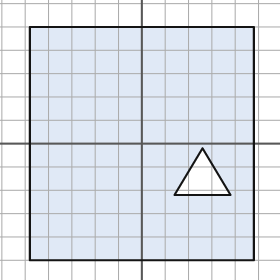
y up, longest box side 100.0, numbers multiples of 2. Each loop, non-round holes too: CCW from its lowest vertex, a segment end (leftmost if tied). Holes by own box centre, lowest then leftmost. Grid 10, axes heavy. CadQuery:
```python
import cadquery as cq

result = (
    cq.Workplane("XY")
    .moveTo(-48.0, -50.0)
    .lineTo(48.0, -50.0)
    .lineTo(48.0, 50.0)
    .lineTo(-48.0, 50.0)
    .close()
    .moveTo(14.0, -22.0)
    .lineTo(38.0, -22.0)
    .lineTo(26.0, -2.0)
    .close()
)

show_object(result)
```